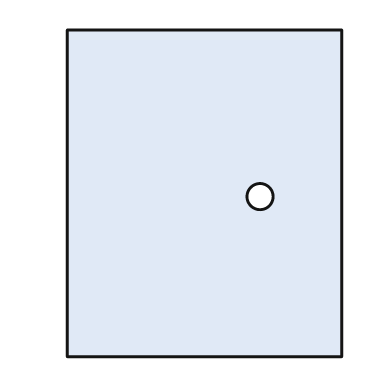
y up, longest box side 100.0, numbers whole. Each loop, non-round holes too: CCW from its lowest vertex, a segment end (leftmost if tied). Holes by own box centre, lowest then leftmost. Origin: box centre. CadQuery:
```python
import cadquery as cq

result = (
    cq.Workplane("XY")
    .moveTo(-42.0, -50.0)
    .lineTo(42.0, -50.0)
    .lineTo(42.0, 50.0)
    .lineTo(-42.0, 50.0)
    .close()
    .moveTo(17.0, -1.0)
    .circle(4.0)
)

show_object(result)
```